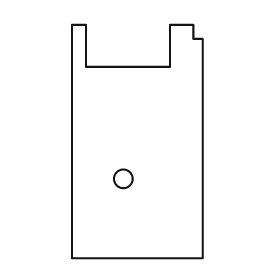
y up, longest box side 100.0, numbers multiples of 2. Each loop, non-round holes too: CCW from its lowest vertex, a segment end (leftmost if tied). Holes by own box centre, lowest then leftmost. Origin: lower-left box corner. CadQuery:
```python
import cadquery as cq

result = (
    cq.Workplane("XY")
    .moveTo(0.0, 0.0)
    .lineTo(56.0, 0.0)
    .lineTo(56.0, 94.0)
    .lineTo(52.0, 94.0)
    .lineTo(52.0, 100.0)
    .lineTo(42.0, 100.0)
    .lineTo(42.0, 82.0)
    .lineTo(6.0, 82.0)
    .lineTo(6.0, 100.0)
    .lineTo(0.0, 100.0)
    .close()
    .moveTo(22.0, 34.0)
    .circle(4.0)
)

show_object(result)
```